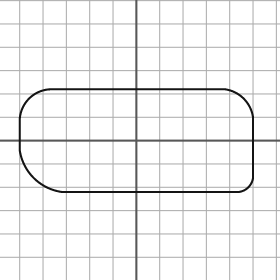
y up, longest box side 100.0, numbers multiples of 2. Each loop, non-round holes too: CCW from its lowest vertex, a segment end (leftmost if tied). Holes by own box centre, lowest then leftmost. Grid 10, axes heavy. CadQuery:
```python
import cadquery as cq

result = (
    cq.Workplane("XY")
    .moveTo(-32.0, -22.0)
    .lineTo(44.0, -22.0)
    .threePointArc((48.0, -20.0), (50.0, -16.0))
    .lineTo(50.0, 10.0)
    .threePointArc((46.0, 18.0), (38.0, 22.0))
    .lineTo(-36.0, 22.0)
    .threePointArc((-46.0, 18.0), (-50.0, 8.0))
    .lineTo(-50.0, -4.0)
    .threePointArc((-44.0, -16.0), (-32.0, -22.0))
    .close()
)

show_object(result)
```